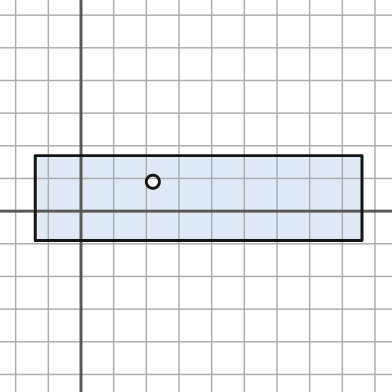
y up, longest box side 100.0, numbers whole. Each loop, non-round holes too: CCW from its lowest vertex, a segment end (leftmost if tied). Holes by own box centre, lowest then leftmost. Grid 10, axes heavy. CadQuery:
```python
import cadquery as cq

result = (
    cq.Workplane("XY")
    .moveTo(-14.0, -9.0)
    .lineTo(86.0, -9.0)
    .lineTo(86.0, 17.0)
    .lineTo(-14.0, 17.0)
    .close()
    .moveTo(22.0, 9.0)
    .circle(2.0)
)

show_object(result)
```